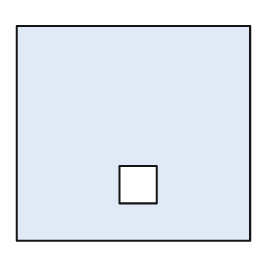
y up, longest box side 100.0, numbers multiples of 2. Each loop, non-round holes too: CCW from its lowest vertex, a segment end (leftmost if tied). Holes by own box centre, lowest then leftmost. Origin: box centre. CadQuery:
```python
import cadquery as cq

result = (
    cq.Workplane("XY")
    .moveTo(-50.0, -46.0)
    .lineTo(50.0, -46.0)
    .lineTo(50.0, 46.0)
    .lineTo(-50.0, 46.0)
    .close()
    .moveTo(-6.0, -30.0)
    .lineTo(10.0, -30.0)
    .lineTo(10.0, -14.0)
    .lineTo(-6.0, -14.0)
    .close()
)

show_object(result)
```